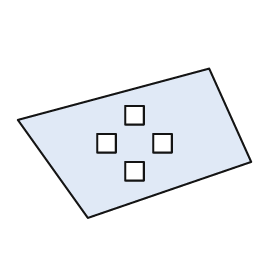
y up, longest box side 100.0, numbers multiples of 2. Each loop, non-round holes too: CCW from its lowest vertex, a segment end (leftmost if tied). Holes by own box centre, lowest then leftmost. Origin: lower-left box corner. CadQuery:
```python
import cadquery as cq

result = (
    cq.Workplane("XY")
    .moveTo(30.0, 0.0)
    .lineTo(100.0, 24.0)
    .lineTo(82.0, 64.0)
    .lineTo(0.0, 42.0)
    .close()
    .moveTo(46.0, 16.0)
    .lineTo(54.0, 16.0)
    .lineTo(54.0, 24.0)
    .lineTo(46.0, 24.0)
    .close()
    .moveTo(34.0, 28.0)
    .lineTo(42.0, 28.0)
    .lineTo(42.0, 36.0)
    .lineTo(34.0, 36.0)
    .close()
    .moveTo(58.0, 28.0)
    .lineTo(66.0, 28.0)
    .lineTo(66.0, 36.0)
    .lineTo(58.0, 36.0)
    .close()
    .moveTo(46.0, 40.0)
    .lineTo(54.0, 40.0)
    .lineTo(54.0, 48.0)
    .lineTo(46.0, 48.0)
    .close()
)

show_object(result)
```